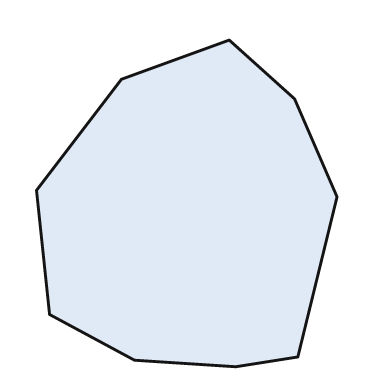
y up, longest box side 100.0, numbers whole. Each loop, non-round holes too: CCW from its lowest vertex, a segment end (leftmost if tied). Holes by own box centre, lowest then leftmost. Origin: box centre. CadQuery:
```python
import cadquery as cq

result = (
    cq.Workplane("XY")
    .moveTo(15.0, -50.0)
    .lineTo(34.0, -47.0)
    .lineTo(46.0, 2.0)
    .lineTo(33.0, 32.0)
    .lineTo(13.0, 50.0)
    .lineTo(-20.0, 38.0)
    .lineTo(-46.0, 4.0)
    .lineTo(-42.0, -34.0)
    .lineTo(-16.0, -48.0)
    .close()
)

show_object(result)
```